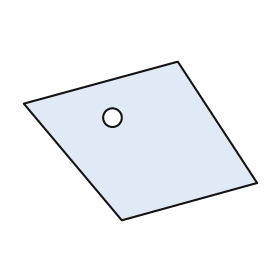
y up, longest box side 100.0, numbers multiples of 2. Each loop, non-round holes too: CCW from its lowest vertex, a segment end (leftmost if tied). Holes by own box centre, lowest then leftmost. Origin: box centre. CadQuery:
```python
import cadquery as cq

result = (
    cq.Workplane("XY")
    .moveTo(-8.0, -34.0)
    .lineTo(50.0, -18.0)
    .lineTo(16.0, 34.0)
    .lineTo(-50.0, 16.0)
    .close()
    .moveTo(-12.0, 10.0)
    .circle(4.0)
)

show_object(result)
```